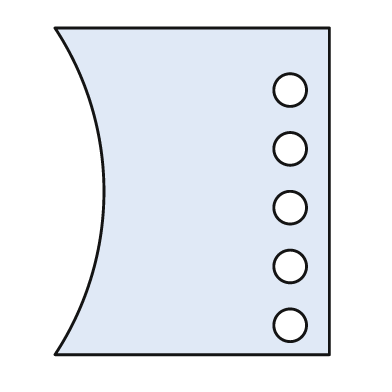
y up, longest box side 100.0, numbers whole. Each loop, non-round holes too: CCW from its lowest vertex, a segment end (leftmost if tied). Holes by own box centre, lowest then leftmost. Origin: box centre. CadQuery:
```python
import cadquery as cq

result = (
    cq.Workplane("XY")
    .moveTo(-42.0, -50.0)
    .lineTo(42.0, -50.0)
    .lineTo(42.0, 50.0)
    .lineTo(-42.0, 50.0)
    .threePointArc((-27.0, 0.0), (-42.0, -50.0))
    .close()
    .moveTo(30.0, -41.0)
    .circle(5.0)
    .moveTo(30.0, -23.0)
    .circle(5.0)
    .moveTo(30.0, -5.0)
    .circle(5.0)
    .moveTo(30.0, 13.0)
    .circle(5.0)
    .moveTo(30.0, 31.0)
    .circle(5.0)
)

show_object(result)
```